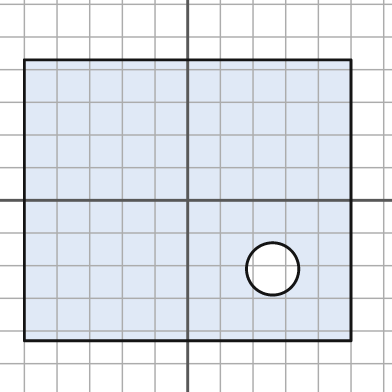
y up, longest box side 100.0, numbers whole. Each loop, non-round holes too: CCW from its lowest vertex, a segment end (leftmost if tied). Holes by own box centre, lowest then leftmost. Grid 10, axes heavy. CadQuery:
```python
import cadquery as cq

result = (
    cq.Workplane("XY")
    .moveTo(-50.0, -43.0)
    .lineTo(50.0, -43.0)
    .lineTo(50.0, 43.0)
    .lineTo(-50.0, 43.0)
    .close()
    .moveTo(26.0, -21.0)
    .circle(8.0)
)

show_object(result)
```